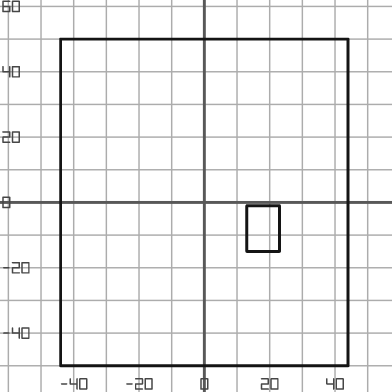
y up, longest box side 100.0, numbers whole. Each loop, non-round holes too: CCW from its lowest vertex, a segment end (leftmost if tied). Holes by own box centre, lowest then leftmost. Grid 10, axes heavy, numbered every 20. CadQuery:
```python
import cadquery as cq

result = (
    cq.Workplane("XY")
    .moveTo(-44.0, -50.0)
    .lineTo(44.0, -50.0)
    .lineTo(44.0, 50.0)
    .lineTo(-44.0, 50.0)
    .close()
    .moveTo(13.0, -15.0)
    .lineTo(23.0, -15.0)
    .lineTo(23.0, -1.0)
    .lineTo(13.0, -1.0)
    .close()
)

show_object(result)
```